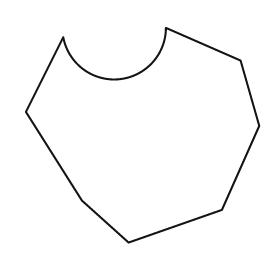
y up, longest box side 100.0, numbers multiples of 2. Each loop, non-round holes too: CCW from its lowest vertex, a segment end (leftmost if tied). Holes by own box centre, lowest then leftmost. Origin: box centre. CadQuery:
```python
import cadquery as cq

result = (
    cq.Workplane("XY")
    .moveTo(-6.0, -46.0)
    .lineTo(34.0, -32.0)
    .lineTo(50.0, 4.0)
    .lineTo(42.0, 32.0)
    .lineTo(10.0, 46.0)
    .threePointArc((-10.0, 24.0), (-34.0, 42.0))
    .lineTo(-50.0, 10.0)
    .lineTo(-26.0, -28.0)
    .close()
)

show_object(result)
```